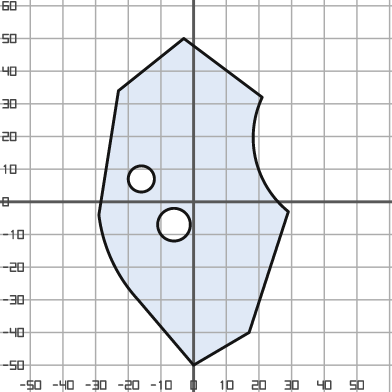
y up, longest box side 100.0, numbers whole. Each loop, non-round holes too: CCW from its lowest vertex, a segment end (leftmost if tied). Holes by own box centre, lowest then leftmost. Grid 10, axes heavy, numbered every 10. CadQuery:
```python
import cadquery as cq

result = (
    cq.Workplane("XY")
    .moveTo(0.0, -50.0)
    .lineTo(17.0, -40.0)
    .lineTo(29.0, -3.0)
    .threePointArc((19.0, 13.0), (21.0, 32.0))
    .lineTo(-3.0, 50.0)
    .lineTo(-23.0, 34.0)
    .lineTo(-29.0, -4.0)
    .threePointArc((-25.0, -18.0), (-17.0, -30.0))
    .close()
    .moveTo(-6.0, -7.0)
    .circle(5.0)
    .moveTo(-16.0, 7.0)
    .circle(4.0)
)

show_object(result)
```